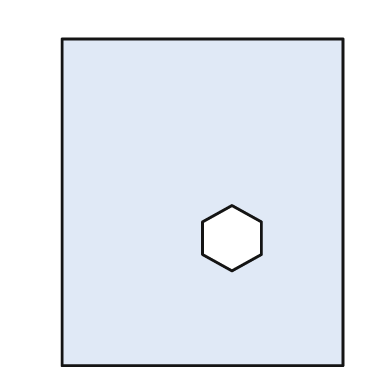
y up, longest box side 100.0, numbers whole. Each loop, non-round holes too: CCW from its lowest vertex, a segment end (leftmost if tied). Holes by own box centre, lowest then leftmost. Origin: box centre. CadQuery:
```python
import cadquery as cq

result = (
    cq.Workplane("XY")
    .moveTo(-43.0, -50.0)
    .lineTo(43.0, -50.0)
    .lineTo(43.0, 50.0)
    .lineTo(-43.0, 50.0)
    .close()
    .moveTo(9.0, -21.0)
    .lineTo(18.0, -16.0)
    .lineTo(18.0, -6.0)
    .lineTo(9.0, -1.0)
    .lineTo(0.0, -6.0)
    .lineTo(0.0, -16.0)
    .close()
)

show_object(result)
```